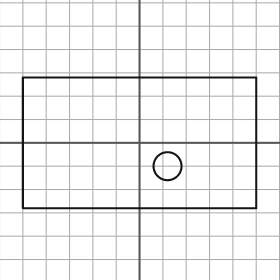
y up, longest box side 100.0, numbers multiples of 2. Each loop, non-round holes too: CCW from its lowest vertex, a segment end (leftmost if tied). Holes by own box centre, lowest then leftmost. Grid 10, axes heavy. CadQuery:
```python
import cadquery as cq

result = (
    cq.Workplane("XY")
    .moveTo(-50.0, -28.0)
    .lineTo(50.0, -28.0)
    .lineTo(50.0, 28.0)
    .lineTo(-50.0, 28.0)
    .close()
    .moveTo(12.0, -10.0)
    .circle(6.0)
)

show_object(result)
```